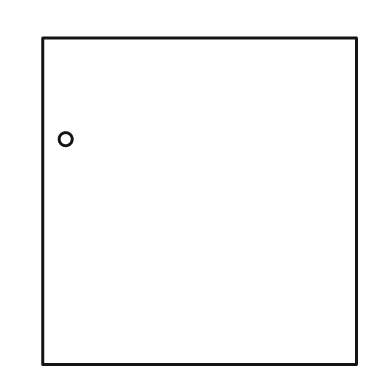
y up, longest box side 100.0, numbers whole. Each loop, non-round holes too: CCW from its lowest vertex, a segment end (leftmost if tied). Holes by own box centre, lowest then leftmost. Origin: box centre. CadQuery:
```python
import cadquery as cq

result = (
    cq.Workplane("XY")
    .moveTo(-48.0, -50.0)
    .lineTo(48.0, -50.0)
    .lineTo(48.0, 50.0)
    .lineTo(-48.0, 50.0)
    .close()
    .moveTo(-41.0, 19.0)
    .circle(2.0)
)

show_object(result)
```